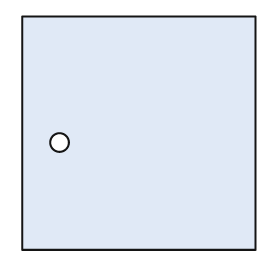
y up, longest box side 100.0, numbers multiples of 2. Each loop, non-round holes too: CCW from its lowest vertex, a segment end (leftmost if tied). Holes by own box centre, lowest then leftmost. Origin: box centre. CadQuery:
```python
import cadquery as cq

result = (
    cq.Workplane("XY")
    .moveTo(-50.0, -50.0)
    .lineTo(50.0, -50.0)
    .lineTo(50.0, 50.0)
    .lineTo(-50.0, 50.0)
    .close()
    .moveTo(-34.0, -4.0)
    .circle(4.0)
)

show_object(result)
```